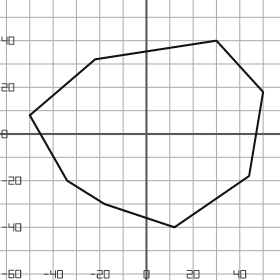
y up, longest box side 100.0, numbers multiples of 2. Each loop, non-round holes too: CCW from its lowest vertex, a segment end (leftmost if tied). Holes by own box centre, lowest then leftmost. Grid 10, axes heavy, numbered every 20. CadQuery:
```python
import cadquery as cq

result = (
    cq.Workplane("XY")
    .moveTo(12.0, -40.0)
    .lineTo(44.0, -18.0)
    .lineTo(50.0, 18.0)
    .lineTo(30.0, 40.0)
    .lineTo(-22.0, 32.0)
    .lineTo(-50.0, 8.0)
    .lineTo(-34.0, -20.0)
    .lineTo(-18.0, -30.0)
    .close()
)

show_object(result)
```